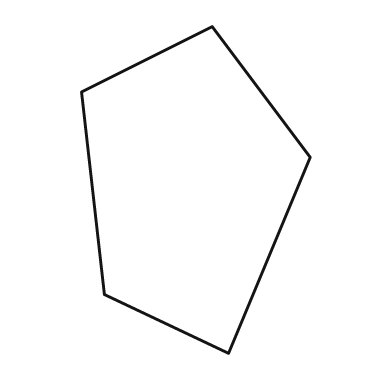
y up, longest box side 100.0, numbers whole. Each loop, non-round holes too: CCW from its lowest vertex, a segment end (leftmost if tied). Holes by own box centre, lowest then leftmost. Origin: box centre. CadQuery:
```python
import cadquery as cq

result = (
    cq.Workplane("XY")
    .moveTo(10.0, -50.0)
    .lineTo(35.0, 10.0)
    .lineTo(5.0, 50.0)
    .lineTo(-35.0, 30.0)
    .lineTo(-28.0, -32.0)
    .close()
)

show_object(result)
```